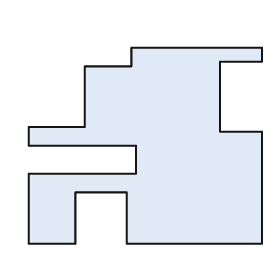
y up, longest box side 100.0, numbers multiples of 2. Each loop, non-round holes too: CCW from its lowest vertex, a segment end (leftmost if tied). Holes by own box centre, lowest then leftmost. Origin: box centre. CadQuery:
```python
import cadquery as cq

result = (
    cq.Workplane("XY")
    .moveTo(-50.0, -42.0)
    .lineTo(-30.0, -42.0)
    .lineTo(-30.0, -20.0)
    .lineTo(-8.0, -20.0)
    .lineTo(-8.0, -42.0)
    .lineTo(50.0, -42.0)
    .lineTo(50.0, 6.0)
    .lineTo(32.0, 6.0)
    .lineTo(32.0, 36.0)
    .lineTo(50.0, 36.0)
    .lineTo(50.0, 42.0)
    .lineTo(-6.0, 42.0)
    .lineTo(-6.0, 34.0)
    .lineTo(-26.0, 34.0)
    .lineTo(-26.0, 8.0)
    .lineTo(-50.0, 8.0)
    .lineTo(-50.0, 0.0)
    .lineTo(-4.0, 0.0)
    .lineTo(-4.0, -12.0)
    .lineTo(-50.0, -12.0)
    .close()
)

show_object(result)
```